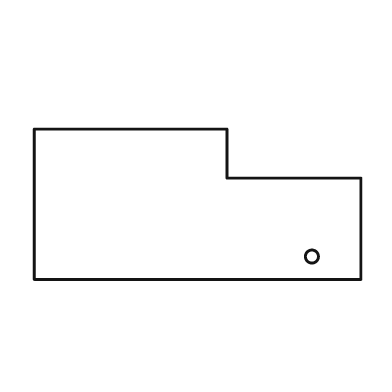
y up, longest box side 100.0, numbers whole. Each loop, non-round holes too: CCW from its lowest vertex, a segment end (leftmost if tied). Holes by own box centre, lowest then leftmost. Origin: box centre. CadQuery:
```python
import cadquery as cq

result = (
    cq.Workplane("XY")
    .moveTo(-50.0, -23.0)
    .lineTo(50.0, -23.0)
    .lineTo(50.0, 8.0)
    .lineTo(9.0, 8.0)
    .lineTo(9.0, 23.0)
    .lineTo(-50.0, 23.0)
    .close()
    .moveTo(35.0, -16.0)
    .circle(2.0)
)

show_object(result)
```